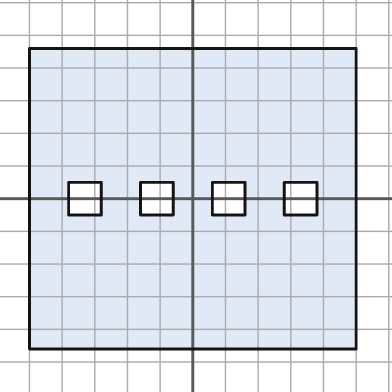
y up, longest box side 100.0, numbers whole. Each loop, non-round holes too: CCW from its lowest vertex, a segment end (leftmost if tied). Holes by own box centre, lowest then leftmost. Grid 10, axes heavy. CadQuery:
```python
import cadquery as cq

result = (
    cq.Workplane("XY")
    .moveTo(-50.0, -46.0)
    .lineTo(50.0, -46.0)
    .lineTo(50.0, 46.0)
    .lineTo(-50.0, 46.0)
    .close()
    .moveTo(-38.0, -5.0)
    .lineTo(-28.0, -5.0)
    .lineTo(-28.0, 5.0)
    .lineTo(-38.0, 5.0)
    .close()
    .moveTo(-16.0, -5.0)
    .lineTo(-6.0, -5.0)
    .lineTo(-6.0, 5.0)
    .lineTo(-16.0, 5.0)
    .close()
    .moveTo(6.0, -5.0)
    .lineTo(16.0, -5.0)
    .lineTo(16.0, 5.0)
    .lineTo(6.0, 5.0)
    .close()
    .moveTo(28.0, -5.0)
    .lineTo(38.0, -5.0)
    .lineTo(38.0, 5.0)
    .lineTo(28.0, 5.0)
    .close()
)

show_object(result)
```